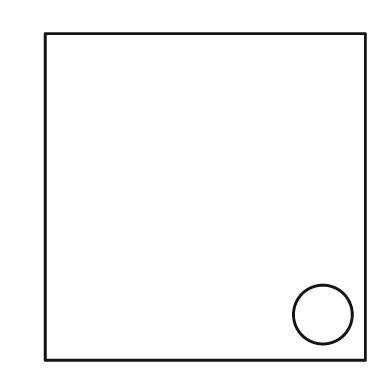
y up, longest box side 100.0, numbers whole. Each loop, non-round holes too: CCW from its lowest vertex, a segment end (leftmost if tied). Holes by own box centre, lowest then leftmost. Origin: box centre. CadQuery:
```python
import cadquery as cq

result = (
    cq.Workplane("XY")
    .moveTo(-49.0, -50.0)
    .lineTo(49.0, -50.0)
    .lineTo(49.0, 50.0)
    .lineTo(-49.0, 50.0)
    .close()
    .moveTo(36.0, -36.0)
    .circle(9.0)
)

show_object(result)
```